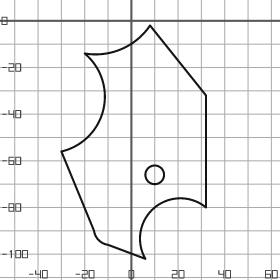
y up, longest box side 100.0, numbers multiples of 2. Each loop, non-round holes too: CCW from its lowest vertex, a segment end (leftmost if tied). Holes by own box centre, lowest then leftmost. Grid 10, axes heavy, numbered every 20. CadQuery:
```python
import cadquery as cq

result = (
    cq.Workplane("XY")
    .moveTo(6.0, -102.0)
    .threePointArc((10.0, -80.0), (32.0, -80.0))
    .lineTo(32.0, -32.0)
    .lineTo(8.0, -2.0)
    .threePointArc((-4.0, -12.0), (-20.0, -14.0))
    .threePointArc((-12.0, -38.0), (-30.0, -56.0))
    .lineTo(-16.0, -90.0)
    .threePointArc((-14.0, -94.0), (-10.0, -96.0))
    .close()
    .moveTo(10.0, -66.0)
    .circle(4.0)
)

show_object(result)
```